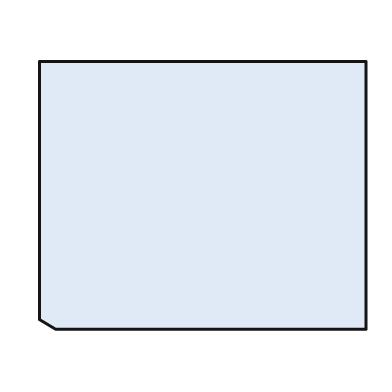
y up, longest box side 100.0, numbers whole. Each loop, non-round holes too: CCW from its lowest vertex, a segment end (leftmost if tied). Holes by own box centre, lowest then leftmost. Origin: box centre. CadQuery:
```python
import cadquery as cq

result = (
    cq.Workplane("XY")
    .moveTo(-45.0, -41.0)
    .lineTo(50.0, -41.0)
    .lineTo(50.0, 41.0)
    .lineTo(-50.0, 41.0)
    .lineTo(-50.0, -38.0)
    .close()
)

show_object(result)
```